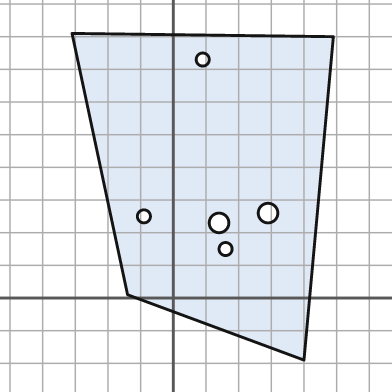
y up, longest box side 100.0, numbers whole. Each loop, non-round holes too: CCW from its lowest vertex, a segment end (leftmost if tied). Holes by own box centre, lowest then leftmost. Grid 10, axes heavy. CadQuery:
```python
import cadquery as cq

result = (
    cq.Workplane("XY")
    .moveTo(40.0, -19.0)
    .lineTo(49.0, 80.0)
    .lineTo(-31.0, 81.0)
    .lineTo(-14.0, 1.0)
    .close()
    .moveTo(16.0, 15.0)
    .circle(2.0)
    .moveTo(14.0, 23.0)
    .circle(3.0)
    .moveTo(-9.0, 25.0)
    .circle(2.0)
    .moveTo(29.0, 26.0)
    .circle(3.0)
    .moveTo(9.0, 73.0)
    .circle(2.0)
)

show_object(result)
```